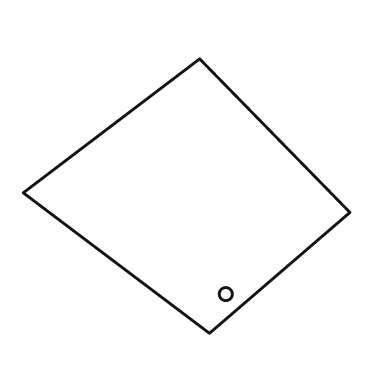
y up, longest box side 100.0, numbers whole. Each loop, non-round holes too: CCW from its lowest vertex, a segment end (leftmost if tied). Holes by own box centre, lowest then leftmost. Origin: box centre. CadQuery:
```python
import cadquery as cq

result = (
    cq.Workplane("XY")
    .moveTo(7.0, -42.0)
    .lineTo(50.0, -5.0)
    .lineTo(4.0, 42.0)
    .lineTo(-50.0, 1.0)
    .close()
    .moveTo(12.0, -30.0)
    .circle(2.0)
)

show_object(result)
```